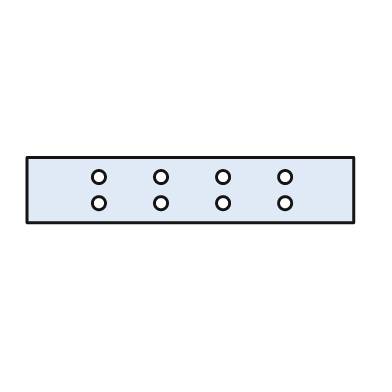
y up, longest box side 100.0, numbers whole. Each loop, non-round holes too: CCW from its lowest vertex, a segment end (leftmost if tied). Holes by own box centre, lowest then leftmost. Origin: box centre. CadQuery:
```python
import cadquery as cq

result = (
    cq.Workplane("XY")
    .moveTo(-50.0, -10.0)
    .lineTo(50.0, -10.0)
    .lineTo(50.0, 10.0)
    .lineTo(-50.0, 10.0)
    .close()
    .moveTo(-28.0, -4.0)
    .circle(2.0)
    .moveTo(-9.0, -4.0)
    .circle(2.0)
    .moveTo(10.0, -4.0)
    .circle(2.0)
    .moveTo(29.0, -4.0)
    .circle(2.0)
    .moveTo(-28.0, 4.0)
    .circle(2.0)
    .moveTo(-9.0, 4.0)
    .circle(2.0)
    .moveTo(10.0, 4.0)
    .circle(2.0)
    .moveTo(29.0, 4.0)
    .circle(2.0)
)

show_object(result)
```